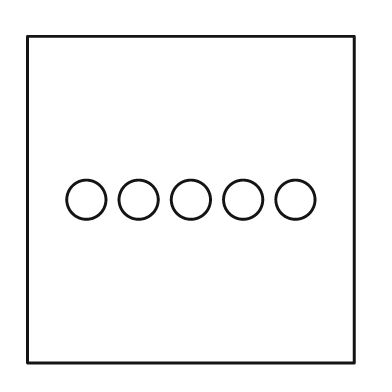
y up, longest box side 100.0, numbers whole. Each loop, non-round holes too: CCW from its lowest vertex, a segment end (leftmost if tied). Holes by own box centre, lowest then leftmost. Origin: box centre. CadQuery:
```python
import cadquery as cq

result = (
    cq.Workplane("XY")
    .moveTo(-50.0, -50.0)
    .lineTo(50.0, -50.0)
    .lineTo(50.0, 50.0)
    .lineTo(-50.0, 50.0)
    .close()
    .moveTo(-32.0, 0.0)
    .circle(6.0)
    .moveTo(-16.0, 0.0)
    .circle(6.0)
    .moveTo(0.0, 0.0)
    .circle(6.0)
    .moveTo(16.0, 0.0)
    .circle(6.0)
    .moveTo(32.0, 0.0)
    .circle(6.0)
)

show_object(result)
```